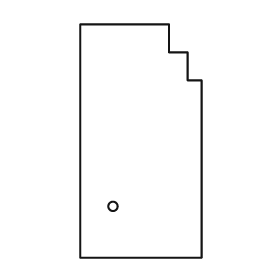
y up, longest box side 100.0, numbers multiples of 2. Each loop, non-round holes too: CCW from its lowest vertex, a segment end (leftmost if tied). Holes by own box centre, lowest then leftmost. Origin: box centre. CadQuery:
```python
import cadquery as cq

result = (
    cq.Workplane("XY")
    .moveTo(-26.0, -50.0)
    .lineTo(26.0, -50.0)
    .lineTo(26.0, 26.0)
    .lineTo(20.0, 26.0)
    .lineTo(20.0, 38.0)
    .lineTo(12.0, 38.0)
    .lineTo(12.0, 50.0)
    .lineTo(-26.0, 50.0)
    .close()
    .moveTo(-12.0, -28.0)
    .circle(2.0)
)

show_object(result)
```